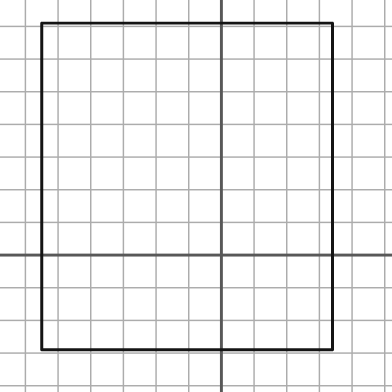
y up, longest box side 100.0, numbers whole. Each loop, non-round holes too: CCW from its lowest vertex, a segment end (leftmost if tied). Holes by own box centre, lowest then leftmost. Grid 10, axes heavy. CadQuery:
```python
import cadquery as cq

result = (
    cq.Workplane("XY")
    .moveTo(-55.0, -29.0)
    .lineTo(34.0, -29.0)
    .lineTo(34.0, 71.0)
    .lineTo(-55.0, 71.0)
    .close()
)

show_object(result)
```